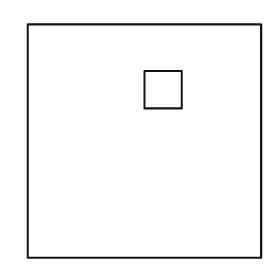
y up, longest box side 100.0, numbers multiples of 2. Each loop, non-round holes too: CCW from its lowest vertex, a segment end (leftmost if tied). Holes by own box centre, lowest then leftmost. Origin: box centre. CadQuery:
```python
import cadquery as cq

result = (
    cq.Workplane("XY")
    .moveTo(-50.0, -50.0)
    .lineTo(50.0, -50.0)
    .lineTo(50.0, 50.0)
    .lineTo(-50.0, 50.0)
    .close()
    .moveTo(0.0, 14.0)
    .lineTo(16.0, 14.0)
    .lineTo(16.0, 30.0)
    .lineTo(0.0, 30.0)
    .close()
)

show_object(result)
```